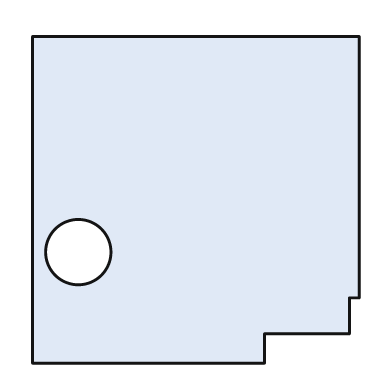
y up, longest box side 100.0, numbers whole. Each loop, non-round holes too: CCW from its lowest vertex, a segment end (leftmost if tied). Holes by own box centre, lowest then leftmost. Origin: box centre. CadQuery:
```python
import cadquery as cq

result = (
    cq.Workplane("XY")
    .moveTo(-50.0, -50.0)
    .lineTo(21.0, -50.0)
    .lineTo(21.0, -41.0)
    .lineTo(47.0, -41.0)
    .lineTo(47.0, -30.0)
    .lineTo(50.0, -30.0)
    .lineTo(50.0, 50.0)
    .lineTo(-50.0, 50.0)
    .close()
    .moveTo(-36.0, -16.0)
    .circle(10.0)
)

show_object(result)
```